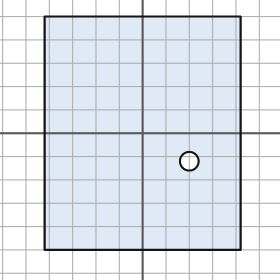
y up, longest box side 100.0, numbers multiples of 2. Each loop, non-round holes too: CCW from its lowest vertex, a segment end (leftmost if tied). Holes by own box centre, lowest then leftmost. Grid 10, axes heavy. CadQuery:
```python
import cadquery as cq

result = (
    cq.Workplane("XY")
    .moveTo(-42.0, -50.0)
    .lineTo(42.0, -50.0)
    .lineTo(42.0, 50.0)
    .lineTo(-42.0, 50.0)
    .close()
    .moveTo(20.0, -12.0)
    .circle(4.0)
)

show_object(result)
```